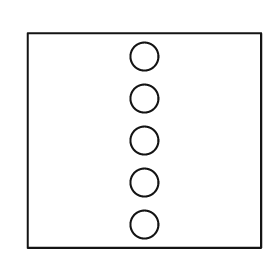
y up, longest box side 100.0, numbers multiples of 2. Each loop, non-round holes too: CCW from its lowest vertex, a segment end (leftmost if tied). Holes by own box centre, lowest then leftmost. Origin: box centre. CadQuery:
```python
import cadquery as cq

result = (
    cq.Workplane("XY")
    .moveTo(-50.0, -46.0)
    .lineTo(50.0, -46.0)
    .lineTo(50.0, 46.0)
    .lineTo(-50.0, 46.0)
    .close()
    .moveTo(0.0, -36.0)
    .circle(6.0)
    .moveTo(0.0, -18.0)
    .circle(6.0)
    .moveTo(0.0, 0.0)
    .circle(6.0)
    .moveTo(0.0, 18.0)
    .circle(6.0)
    .moveTo(0.0, 36.0)
    .circle(6.0)
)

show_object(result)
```